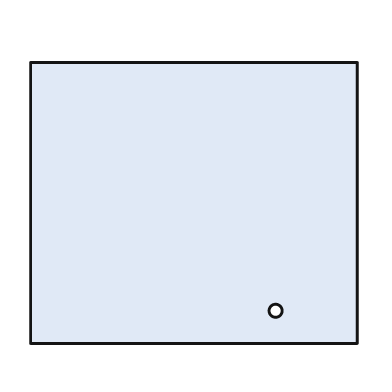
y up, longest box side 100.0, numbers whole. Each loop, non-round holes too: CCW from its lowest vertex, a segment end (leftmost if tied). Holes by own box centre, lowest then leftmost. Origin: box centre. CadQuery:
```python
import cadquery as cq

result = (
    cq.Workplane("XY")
    .moveTo(-50.0, -43.0)
    .lineTo(50.0, -43.0)
    .lineTo(50.0, 43.0)
    .lineTo(-50.0, 43.0)
    .close()
    .moveTo(25.0, -33.0)
    .circle(2.0)
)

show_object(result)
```